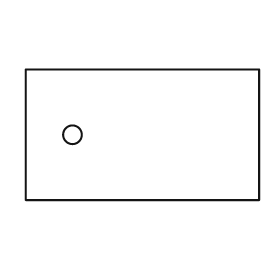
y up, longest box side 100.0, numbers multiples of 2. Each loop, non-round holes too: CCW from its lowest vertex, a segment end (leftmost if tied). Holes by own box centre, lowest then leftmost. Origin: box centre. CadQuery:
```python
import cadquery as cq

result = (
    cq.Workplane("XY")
    .moveTo(-50.0, -28.0)
    .lineTo(50.0, -28.0)
    .lineTo(50.0, 28.0)
    .lineTo(-50.0, 28.0)
    .close()
    .moveTo(-30.0, 0.0)
    .circle(4.0)
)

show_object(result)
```